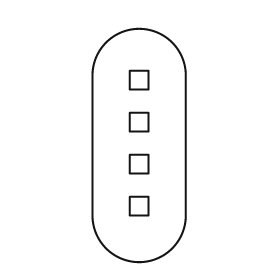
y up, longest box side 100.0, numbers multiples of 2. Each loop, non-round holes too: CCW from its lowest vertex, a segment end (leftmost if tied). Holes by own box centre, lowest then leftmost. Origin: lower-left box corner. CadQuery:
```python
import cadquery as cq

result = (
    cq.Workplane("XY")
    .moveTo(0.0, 20.0)
    .threePointArc((20.0, 0.0), (40.0, 20.0))
    .lineTo(40.0, 80.0)
    .threePointArc((20.0, 100.0), (0.0, 80.0))
    .close()
    .moveTo(16.0, 20.0)
    .lineTo(24.0, 20.0)
    .lineTo(24.0, 28.0)
    .lineTo(16.0, 28.0)
    .close()
    .moveTo(16.0, 38.0)
    .lineTo(24.0, 38.0)
    .lineTo(24.0, 46.0)
    .lineTo(16.0, 46.0)
    .close()
    .moveTo(16.0, 56.0)
    .lineTo(24.0, 56.0)
    .lineTo(24.0, 64.0)
    .lineTo(16.0, 64.0)
    .close()
    .moveTo(16.0, 74.0)
    .lineTo(24.0, 74.0)
    .lineTo(24.0, 82.0)
    .lineTo(16.0, 82.0)
    .close()
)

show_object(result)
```